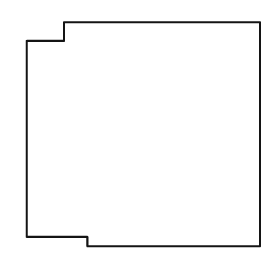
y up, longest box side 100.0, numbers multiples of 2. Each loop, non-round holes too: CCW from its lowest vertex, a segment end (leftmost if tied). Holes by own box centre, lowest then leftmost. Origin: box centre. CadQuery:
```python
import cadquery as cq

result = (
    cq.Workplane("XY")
    .moveTo(-24.0, -48.0)
    .lineTo(50.0, -48.0)
    .lineTo(50.0, 48.0)
    .lineTo(-34.0, 48.0)
    .lineTo(-34.0, 40.0)
    .lineTo(-50.0, 40.0)
    .lineTo(-50.0, -44.0)
    .lineTo(-24.0, -44.0)
    .close()
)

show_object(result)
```